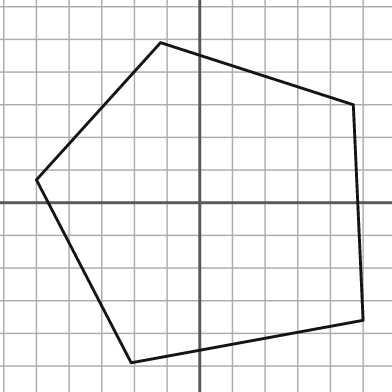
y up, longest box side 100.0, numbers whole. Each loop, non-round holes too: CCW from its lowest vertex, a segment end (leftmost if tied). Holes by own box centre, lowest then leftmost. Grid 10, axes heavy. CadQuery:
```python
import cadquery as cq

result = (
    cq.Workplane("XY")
    .moveTo(-21.0, -49.0)
    .lineTo(50.0, -36.0)
    .lineTo(47.0, 30.0)
    .lineTo(-12.0, 49.0)
    .lineTo(-50.0, 7.0)
    .close()
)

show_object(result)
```